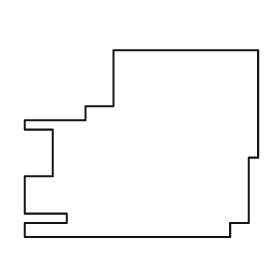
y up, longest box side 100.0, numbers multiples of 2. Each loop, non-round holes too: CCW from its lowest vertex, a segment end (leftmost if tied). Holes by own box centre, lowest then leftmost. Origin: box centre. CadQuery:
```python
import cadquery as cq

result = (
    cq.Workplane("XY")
    .moveTo(-50.0, -40.0)
    .lineTo(38.0, -40.0)
    .lineTo(38.0, -34.0)
    .lineTo(46.0, -34.0)
    .lineTo(46.0, -6.0)
    .lineTo(50.0, -6.0)
    .lineTo(50.0, 40.0)
    .lineTo(-12.0, 40.0)
    .lineTo(-12.0, 16.0)
    .lineTo(-24.0, 16.0)
    .lineTo(-24.0, 10.0)
    .lineTo(-50.0, 10.0)
    .lineTo(-50.0, 6.0)
    .lineTo(-38.0, 6.0)
    .lineTo(-38.0, -14.0)
    .lineTo(-50.0, -14.0)
    .lineTo(-50.0, -30.0)
    .lineTo(-32.0, -30.0)
    .lineTo(-32.0, -34.0)
    .lineTo(-50.0, -34.0)
    .close()
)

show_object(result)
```